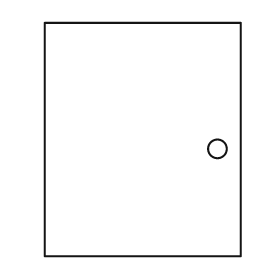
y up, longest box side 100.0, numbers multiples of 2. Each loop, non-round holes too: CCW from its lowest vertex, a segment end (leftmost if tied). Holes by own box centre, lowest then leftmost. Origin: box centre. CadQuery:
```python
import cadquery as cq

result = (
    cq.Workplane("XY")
    .moveTo(-42.0, -50.0)
    .lineTo(42.0, -50.0)
    .lineTo(42.0, 50.0)
    .lineTo(-42.0, 50.0)
    .close()
    .moveTo(32.0, -4.0)
    .circle(4.0)
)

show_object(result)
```